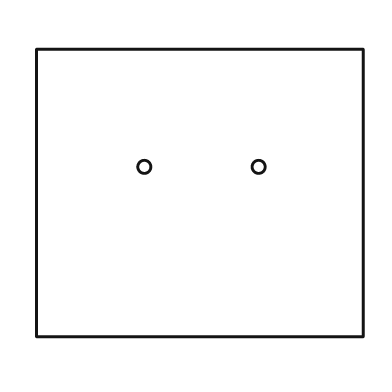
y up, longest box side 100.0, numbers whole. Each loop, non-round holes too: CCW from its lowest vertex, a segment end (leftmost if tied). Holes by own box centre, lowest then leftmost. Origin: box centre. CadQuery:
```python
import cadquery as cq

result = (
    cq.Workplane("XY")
    .moveTo(-50.0, -44.0)
    .lineTo(50.0, -44.0)
    .lineTo(50.0, 44.0)
    .lineTo(-50.0, 44.0)
    .close()
    .moveTo(-17.0, 8.0)
    .circle(2.0)
    .moveTo(18.0, 8.0)
    .circle(2.0)
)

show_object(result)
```